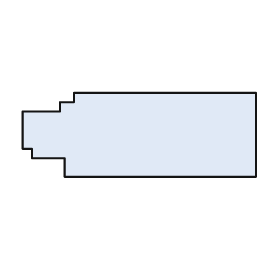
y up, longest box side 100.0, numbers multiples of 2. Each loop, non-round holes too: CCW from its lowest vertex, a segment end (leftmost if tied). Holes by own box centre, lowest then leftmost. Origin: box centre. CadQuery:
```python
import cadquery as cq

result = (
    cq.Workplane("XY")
    .moveTo(-32.0, -18.0)
    .lineTo(50.0, -18.0)
    .lineTo(50.0, 18.0)
    .lineTo(-28.0, 18.0)
    .lineTo(-28.0, 14.0)
    .lineTo(-34.0, 14.0)
    .lineTo(-34.0, 10.0)
    .lineTo(-50.0, 10.0)
    .lineTo(-50.0, -6.0)
    .lineTo(-46.0, -6.0)
    .lineTo(-46.0, -10.0)
    .lineTo(-32.0, -10.0)
    .close()
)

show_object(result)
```